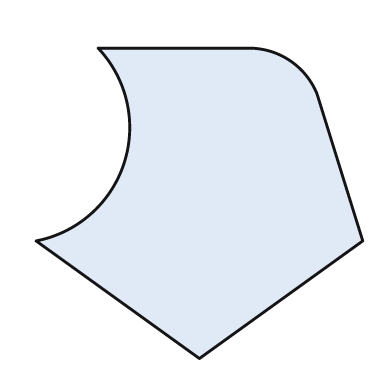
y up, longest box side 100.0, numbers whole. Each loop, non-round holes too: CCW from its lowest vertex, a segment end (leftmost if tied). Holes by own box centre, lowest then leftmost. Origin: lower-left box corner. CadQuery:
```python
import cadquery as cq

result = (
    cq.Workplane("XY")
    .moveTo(50.0, 0.0)
    .lineTo(100.0, 36.0)
    .lineTo(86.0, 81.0)
    .threePointArc((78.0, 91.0), (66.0, 95.0))
    .lineTo(19.0, 95.0)
    .threePointArc((27.0, 60.0), (0.0, 36.0))
    .close()
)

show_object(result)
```